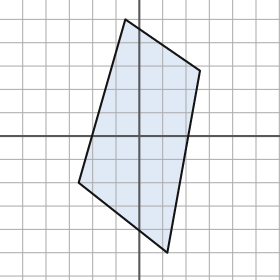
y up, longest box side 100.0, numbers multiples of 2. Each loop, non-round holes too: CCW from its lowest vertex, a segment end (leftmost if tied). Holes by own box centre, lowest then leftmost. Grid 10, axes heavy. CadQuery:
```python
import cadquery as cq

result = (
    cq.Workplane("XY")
    .moveTo(12.0, -50.0)
    .lineTo(26.0, 28.0)
    .lineTo(-6.0, 50.0)
    .lineTo(-26.0, -20.0)
    .close()
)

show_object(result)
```